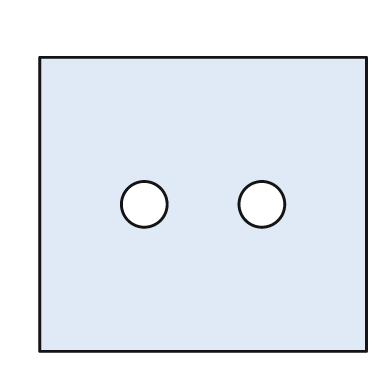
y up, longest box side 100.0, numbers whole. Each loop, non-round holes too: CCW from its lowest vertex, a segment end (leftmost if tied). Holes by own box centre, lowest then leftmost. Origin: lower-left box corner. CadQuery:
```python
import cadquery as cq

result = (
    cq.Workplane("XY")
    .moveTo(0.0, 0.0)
    .lineTo(100.0, 0.0)
    .lineTo(100.0, 90.0)
    .lineTo(0.0, 90.0)
    .close()
    .moveTo(32.0, 45.0)
    .circle(7.0)
    .moveTo(68.0, 45.0)
    .circle(7.0)
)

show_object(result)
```